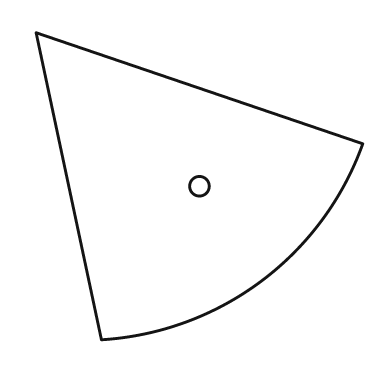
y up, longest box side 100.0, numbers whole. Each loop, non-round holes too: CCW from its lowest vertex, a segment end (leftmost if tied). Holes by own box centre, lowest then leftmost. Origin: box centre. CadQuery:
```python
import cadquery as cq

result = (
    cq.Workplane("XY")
    .moveTo(-30.0, -47.0)
    .threePointArc((19.0, -29.0), (50.0, 13.0))
    .lineTo(-50.0, 47.0)
    .close()
    .moveTo(0.0, 0.0)
    .circle(3.0)
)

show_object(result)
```